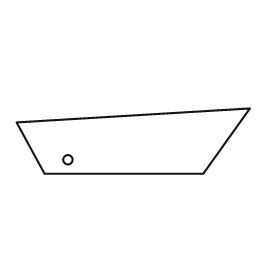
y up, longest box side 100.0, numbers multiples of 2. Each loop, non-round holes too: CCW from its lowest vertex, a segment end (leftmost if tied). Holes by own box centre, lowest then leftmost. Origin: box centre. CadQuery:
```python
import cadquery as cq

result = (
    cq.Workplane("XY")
    .moveTo(-38.0, -14.0)
    .lineTo(30.0, -14.0)
    .lineTo(50.0, 14.0)
    .lineTo(-50.0, 8.0)
    .close()
    .moveTo(-28.0, -8.0)
    .circle(2.0)
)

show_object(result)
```